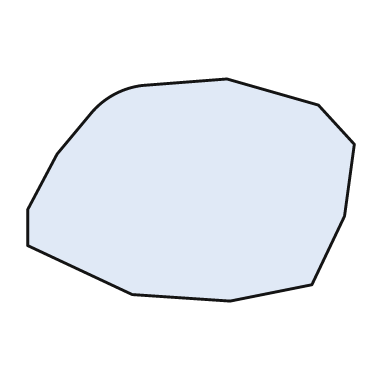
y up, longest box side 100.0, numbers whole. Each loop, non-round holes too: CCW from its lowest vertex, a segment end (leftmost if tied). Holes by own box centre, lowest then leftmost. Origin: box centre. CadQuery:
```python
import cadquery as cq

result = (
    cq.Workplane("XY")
    .moveTo(12.0, -34.0)
    .lineTo(37.0, -29.0)
    .lineTo(47.0, -8.0)
    .lineTo(50.0, 14.0)
    .lineTo(39.0, 26.0)
    .lineTo(11.0, 34.0)
    .lineTo(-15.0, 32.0)
    .threePointArc((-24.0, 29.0), (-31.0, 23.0))
    .lineTo(-41.0, 11.0)
    .lineTo(-50.0, -6.0)
    .lineTo(-50.0, -17.0)
    .lineTo(-18.0, -32.0)
    .close()
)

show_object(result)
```